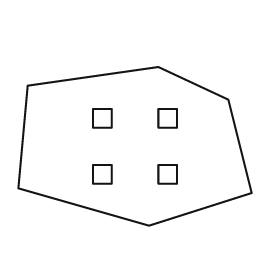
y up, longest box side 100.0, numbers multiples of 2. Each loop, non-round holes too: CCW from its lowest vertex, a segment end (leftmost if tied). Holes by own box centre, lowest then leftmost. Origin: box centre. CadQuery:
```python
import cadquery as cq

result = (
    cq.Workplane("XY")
    .moveTo(6.0, -34.0)
    .lineTo(50.0, -20.0)
    .lineTo(40.0, 20.0)
    .lineTo(10.0, 34.0)
    .lineTo(-46.0, 26.0)
    .lineTo(-50.0, -18.0)
    .close()
    .moveTo(-18.0, -16.0)
    .lineTo(-10.0, -16.0)
    .lineTo(-10.0, -8.0)
    .lineTo(-18.0, -8.0)
    .close()
    .moveTo(10.0, -16.0)
    .lineTo(18.0, -16.0)
    .lineTo(18.0, -8.0)
    .lineTo(10.0, -8.0)
    .close()
    .moveTo(-18.0, 8.0)
    .lineTo(-10.0, 8.0)
    .lineTo(-10.0, 16.0)
    .lineTo(-18.0, 16.0)
    .close()
    .moveTo(10.0, 8.0)
    .lineTo(18.0, 8.0)
    .lineTo(18.0, 16.0)
    .lineTo(10.0, 16.0)
    .close()
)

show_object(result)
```